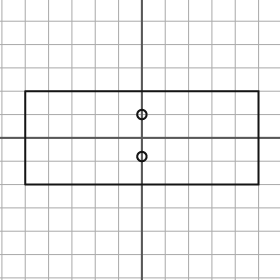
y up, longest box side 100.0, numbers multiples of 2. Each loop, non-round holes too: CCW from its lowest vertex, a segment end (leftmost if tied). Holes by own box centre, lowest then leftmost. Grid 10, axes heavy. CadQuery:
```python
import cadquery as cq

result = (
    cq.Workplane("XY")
    .moveTo(-50.0, -20.0)
    .lineTo(50.0, -20.0)
    .lineTo(50.0, 20.0)
    .lineTo(-50.0, 20.0)
    .close()
    .moveTo(0.0, -8.0)
    .circle(2.0)
    .moveTo(0.0, 10.0)
    .circle(2.0)
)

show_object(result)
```